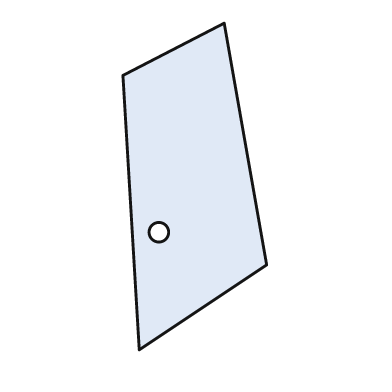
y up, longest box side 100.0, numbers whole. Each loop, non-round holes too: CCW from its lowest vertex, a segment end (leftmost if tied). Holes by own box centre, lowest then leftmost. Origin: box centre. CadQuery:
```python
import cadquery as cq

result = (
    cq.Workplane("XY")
    .moveTo(-17.0, -50.0)
    .lineTo(22.0, -24.0)
    .lineTo(9.0, 50.0)
    .lineTo(-22.0, 34.0)
    .close()
    .moveTo(-11.0, -14.0)
    .circle(3.0)
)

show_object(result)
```